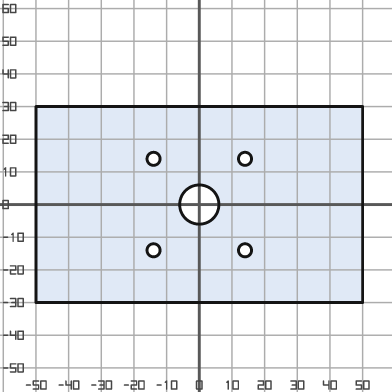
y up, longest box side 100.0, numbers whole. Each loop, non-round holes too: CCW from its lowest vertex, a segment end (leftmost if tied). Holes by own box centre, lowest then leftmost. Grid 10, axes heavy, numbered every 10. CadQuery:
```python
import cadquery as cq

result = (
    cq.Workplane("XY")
    .moveTo(-50.0, -30.0)
    .lineTo(50.0, -30.0)
    .lineTo(50.0, 30.0)
    .lineTo(-50.0, 30.0)
    .close()
    .moveTo(-14.0, -14.0)
    .circle(2.0)
    .moveTo(14.0, -14.0)
    .circle(2.0)
    .moveTo(0.0, 0.0)
    .circle(6.0)
    .moveTo(-14.0, 14.0)
    .circle(2.0)
    .moveTo(14.0, 14.0)
    .circle(2.0)
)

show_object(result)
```